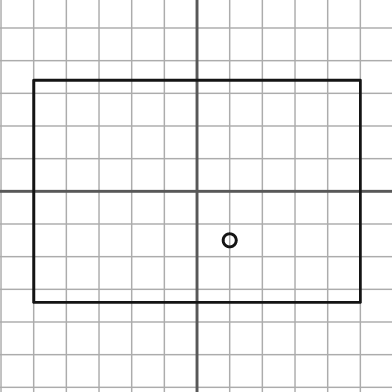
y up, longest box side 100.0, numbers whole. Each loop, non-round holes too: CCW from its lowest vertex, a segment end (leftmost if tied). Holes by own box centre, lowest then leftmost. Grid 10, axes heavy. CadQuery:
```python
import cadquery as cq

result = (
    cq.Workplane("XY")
    .moveTo(-50.0, -34.0)
    .lineTo(50.0, -34.0)
    .lineTo(50.0, 34.0)
    .lineTo(-50.0, 34.0)
    .close()
    .moveTo(10.0, -15.0)
    .circle(2.0)
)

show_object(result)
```